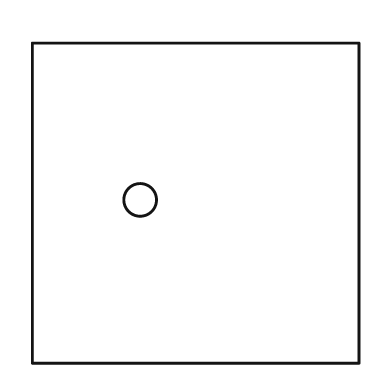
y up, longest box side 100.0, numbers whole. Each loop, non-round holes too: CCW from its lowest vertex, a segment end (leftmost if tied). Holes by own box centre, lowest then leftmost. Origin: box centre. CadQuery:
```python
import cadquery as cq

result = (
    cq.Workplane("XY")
    .moveTo(-50.0, -49.0)
    .lineTo(50.0, -49.0)
    .lineTo(50.0, 49.0)
    .lineTo(-50.0, 49.0)
    .close()
    .moveTo(-17.0, 1.0)
    .circle(5.0)
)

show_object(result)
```